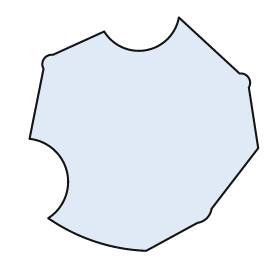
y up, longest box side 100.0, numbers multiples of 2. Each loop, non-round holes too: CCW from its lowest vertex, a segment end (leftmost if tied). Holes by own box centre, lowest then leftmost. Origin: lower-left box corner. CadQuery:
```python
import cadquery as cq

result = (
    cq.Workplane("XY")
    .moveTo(50.0, 0.0)
    .lineTo(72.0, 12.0)
    .threePointArc((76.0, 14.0), (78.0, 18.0))
    .lineTo(98.0, 44.0)
    .lineTo(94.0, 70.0)
    .threePointArc((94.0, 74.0), (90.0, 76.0))
    .lineTo(64.0, 100.0)
    .threePointArc((50.0, 86.0), (32.0, 94.0))
    .lineTo(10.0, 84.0)
    .threePointArc((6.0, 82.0), (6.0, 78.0))
    .lineTo(0.0, 48.0)
    .threePointArc((16.0, 34.0), (8.0, 14.0))
    .threePointArc((28.0, 4.0), (50.0, 0.0))
    .close()
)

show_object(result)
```